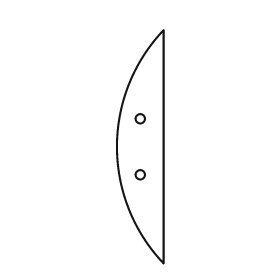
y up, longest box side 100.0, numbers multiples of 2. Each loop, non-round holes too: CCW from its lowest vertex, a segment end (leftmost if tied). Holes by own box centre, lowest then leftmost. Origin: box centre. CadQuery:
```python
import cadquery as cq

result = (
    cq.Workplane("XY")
    .moveTo(10.0, -50.0)
    .lineTo(10.0, 50.0)
    .threePointArc((-10.0, 0.0), (10.0, -50.0))
    .close()
    .moveTo(0.0, -12.0)
    .circle(2.0)
    .moveTo(0.0, 12.0)
    .circle(2.0)
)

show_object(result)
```